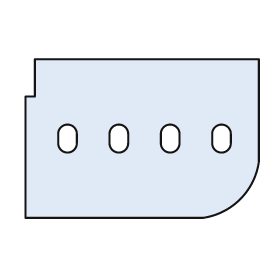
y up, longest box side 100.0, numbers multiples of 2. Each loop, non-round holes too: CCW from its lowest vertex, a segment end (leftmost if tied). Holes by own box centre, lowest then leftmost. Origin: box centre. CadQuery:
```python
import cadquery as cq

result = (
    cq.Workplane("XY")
    .moveTo(-50.0, -34.0)
    .lineTo(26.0, -34.0)
    .threePointArc((42.0, -26.0), (50.0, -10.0))
    .lineTo(50.0, 34.0)
    .lineTo(-46.0, 34.0)
    .lineTo(-46.0, 18.0)
    .lineTo(-50.0, 18.0)
    .close()
    .moveTo(-36.0, -2.0)
    .threePointArc((-32.0, -6.0), (-28.0, -2.0))
    .lineTo(-28.0, 2.0)
    .threePointArc((-32.0, 6.0), (-36.0, 2.0))
    .close()
    .moveTo(-14.0, -2.0)
    .threePointArc((-10.0, -6.0), (-6.0, -2.0))
    .lineTo(-6.0, 2.0)
    .threePointArc((-10.0, 6.0), (-14.0, 2.0))
    .close()
    .moveTo(8.0, -2.0)
    .threePointArc((12.0, -6.0), (16.0, -2.0))
    .lineTo(16.0, 2.0)
    .threePointArc((12.0, 6.0), (8.0, 2.0))
    .close()
    .moveTo(30.0, -2.0)
    .threePointArc((34.0, -6.0), (38.0, -2.0))
    .lineTo(38.0, 2.0)
    .threePointArc((34.0, 6.0), (30.0, 2.0))
    .close()
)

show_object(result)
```